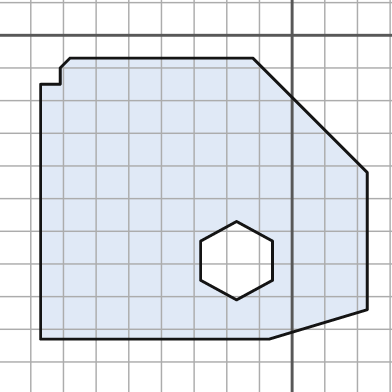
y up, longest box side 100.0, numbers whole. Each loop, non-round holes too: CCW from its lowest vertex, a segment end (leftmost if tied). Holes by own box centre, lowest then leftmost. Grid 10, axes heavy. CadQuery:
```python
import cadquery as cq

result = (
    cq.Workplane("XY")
    .moveTo(-77.0, -93.0)
    .lineTo(-7.0, -93.0)
    .lineTo(23.0, -84.0)
    .lineTo(23.0, -42.0)
    .lineTo(-12.0, -7.0)
    .lineTo(-68.0, -7.0)
    .lineTo(-71.0, -10.0)
    .lineTo(-71.0, -15.0)
    .lineTo(-77.0, -15.0)
    .close()
    .moveTo(-17.0, -81.0)
    .lineTo(-6.0, -75.0)
    .lineTo(-6.0, -63.0)
    .lineTo(-17.0, -57.0)
    .lineTo(-28.0, -63.0)
    .lineTo(-28.0, -75.0)
    .close()
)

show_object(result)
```